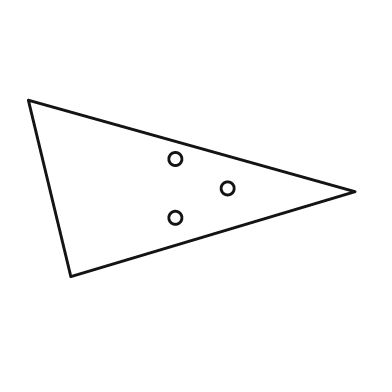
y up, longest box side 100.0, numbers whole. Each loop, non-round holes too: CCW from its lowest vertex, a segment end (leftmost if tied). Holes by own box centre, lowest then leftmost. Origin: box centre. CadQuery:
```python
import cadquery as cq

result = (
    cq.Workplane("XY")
    .moveTo(-37.0, -27.0)
    .lineTo(50.0, -1.0)
    .lineTo(-50.0, 27.0)
    .close()
    .moveTo(-5.0, -9.0)
    .circle(2.0)
    .moveTo(11.0, 0.0)
    .circle(2.0)
    .moveTo(-5.0, 9.0)
    .circle(2.0)
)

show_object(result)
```